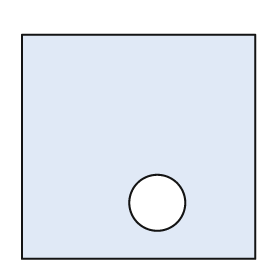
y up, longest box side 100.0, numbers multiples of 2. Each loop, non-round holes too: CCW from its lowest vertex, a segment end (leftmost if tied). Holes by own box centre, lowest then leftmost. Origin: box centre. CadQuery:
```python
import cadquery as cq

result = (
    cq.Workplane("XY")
    .moveTo(-50.0, -48.0)
    .lineTo(50.0, -48.0)
    .lineTo(50.0, 48.0)
    .lineTo(-50.0, 48.0)
    .close()
    .moveTo(8.0, -24.0)
    .circle(12.0)
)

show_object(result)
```